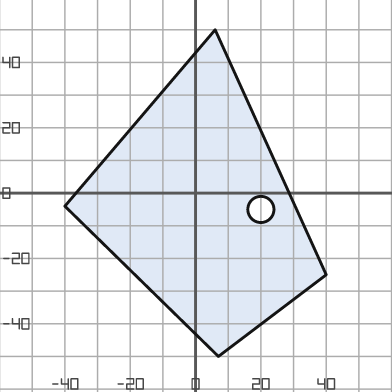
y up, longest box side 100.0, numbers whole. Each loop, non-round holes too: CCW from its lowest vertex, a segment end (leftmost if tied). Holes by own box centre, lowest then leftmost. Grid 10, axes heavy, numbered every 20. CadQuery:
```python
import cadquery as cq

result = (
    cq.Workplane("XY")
    .moveTo(7.0, -50.0)
    .lineTo(40.0, -25.0)
    .lineTo(6.0, 50.0)
    .lineTo(-40.0, -4.0)
    .close()
    .moveTo(20.0, -5.0)
    .circle(4.0)
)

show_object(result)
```